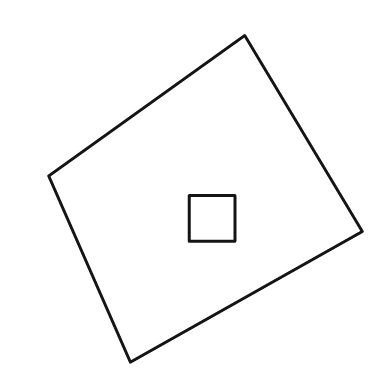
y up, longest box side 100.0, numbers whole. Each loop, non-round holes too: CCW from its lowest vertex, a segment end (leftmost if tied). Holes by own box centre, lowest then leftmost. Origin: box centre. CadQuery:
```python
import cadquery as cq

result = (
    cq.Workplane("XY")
    .moveTo(-23.0, -50.0)
    .lineTo(48.0, -10.0)
    .lineTo(12.0, 50.0)
    .lineTo(-48.0, 7.0)
    .close()
    .moveTo(-5.0, -13.0)
    .lineTo(9.0, -13.0)
    .lineTo(9.0, 1.0)
    .lineTo(-5.0, 1.0)
    .close()
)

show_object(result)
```